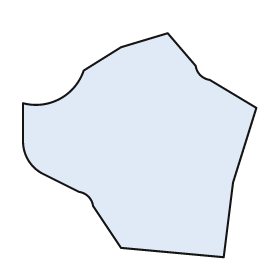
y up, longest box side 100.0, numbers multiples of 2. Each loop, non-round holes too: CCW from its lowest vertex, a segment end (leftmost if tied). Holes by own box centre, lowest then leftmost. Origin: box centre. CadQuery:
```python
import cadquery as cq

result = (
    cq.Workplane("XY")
    .moveTo(36.0, -48.0)
    .lineTo(40.0, -16.0)
    .lineTo(50.0, 16.0)
    .lineTo(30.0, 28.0)
    .threePointArc((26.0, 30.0), (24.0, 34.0))
    .lineTo(12.0, 48.0)
    .lineTo(-8.0, 42.0)
    .lineTo(-24.0, 32.0)
    .threePointArc((-34.0, 20.0), (-50.0, 18.0))
    .lineTo(-50.0, 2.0)
    .threePointArc((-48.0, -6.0), (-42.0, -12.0))
    .lineTo(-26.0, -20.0)
    .threePointArc((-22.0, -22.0), (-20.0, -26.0))
    .lineTo(-8.0, -44.0)
    .close()
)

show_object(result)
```